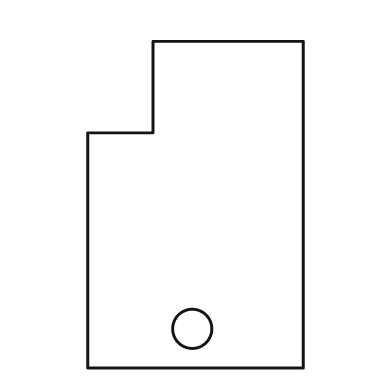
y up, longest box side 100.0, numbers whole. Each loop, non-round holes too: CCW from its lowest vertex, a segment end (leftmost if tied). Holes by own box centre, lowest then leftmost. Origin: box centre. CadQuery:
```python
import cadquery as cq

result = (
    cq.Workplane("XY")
    .moveTo(-33.0, -50.0)
    .lineTo(33.0, -50.0)
    .lineTo(33.0, 50.0)
    .lineTo(-13.0, 50.0)
    .lineTo(-13.0, 22.0)
    .lineTo(-33.0, 22.0)
    .close()
    .moveTo(-1.0, -38.0)
    .circle(6.0)
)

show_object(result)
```